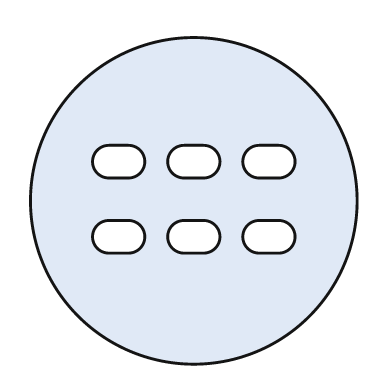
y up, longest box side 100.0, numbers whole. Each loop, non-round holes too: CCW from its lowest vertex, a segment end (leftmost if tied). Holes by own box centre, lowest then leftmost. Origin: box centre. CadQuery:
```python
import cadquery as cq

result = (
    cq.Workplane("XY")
    .moveTo(0.0, 0.0)
    .circle(50.0)
    .moveTo(-26.0, -16.0)
    .lineTo(-20.0, -16.0)
    .threePointArc((-15.0, -11.0), (-20.0, -6.0))
    .lineTo(-26.0, -6.0)
    .threePointArc((-31.0, -11.0), (-26.0, -16.0))
    .close()
    .moveTo(-3.0, -16.0)
    .lineTo(3.0, -16.0)
    .threePointArc((8.0, -11.0), (3.0, -6.0))
    .lineTo(-3.0, -6.0)
    .threePointArc((-8.0, -11.0), (-3.0, -16.0))
    .close()
    .moveTo(20.0, -16.0)
    .lineTo(26.0, -16.0)
    .threePointArc((31.0, -11.0), (26.0, -6.0))
    .lineTo(20.0, -6.0)
    .threePointArc((15.0, -11.0), (20.0, -16.0))
    .close()
    .moveTo(-26.0, 7.0)
    .lineTo(-20.0, 7.0)
    .threePointArc((-15.0, 12.0), (-20.0, 17.0))
    .lineTo(-26.0, 17.0)
    .threePointArc((-31.0, 12.0), (-26.0, 7.0))
    .close()
    .moveTo(-3.0, 7.0)
    .lineTo(3.0, 7.0)
    .threePointArc((8.0, 12.0), (3.0, 17.0))
    .lineTo(-3.0, 17.0)
    .threePointArc((-8.0, 12.0), (-3.0, 7.0))
    .close()
    .moveTo(20.0, 7.0)
    .lineTo(26.0, 7.0)
    .threePointArc((31.0, 12.0), (26.0, 17.0))
    .lineTo(20.0, 17.0)
    .threePointArc((15.0, 12.0), (20.0, 7.0))
    .close()
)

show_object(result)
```